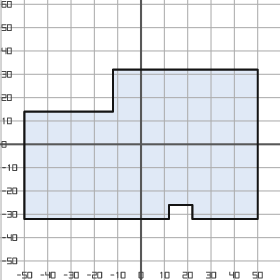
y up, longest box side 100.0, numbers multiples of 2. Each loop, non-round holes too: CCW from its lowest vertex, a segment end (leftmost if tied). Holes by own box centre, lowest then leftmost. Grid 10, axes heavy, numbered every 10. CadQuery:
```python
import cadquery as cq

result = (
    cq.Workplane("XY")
    .moveTo(-50.0, -32.0)
    .lineTo(12.0, -32.0)
    .lineTo(12.0, -26.0)
    .lineTo(22.0, -26.0)
    .lineTo(22.0, -32.0)
    .lineTo(50.0, -32.0)
    .lineTo(50.0, 32.0)
    .lineTo(-12.0, 32.0)
    .lineTo(-12.0, 14.0)
    .lineTo(-50.0, 14.0)
    .close()
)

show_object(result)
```